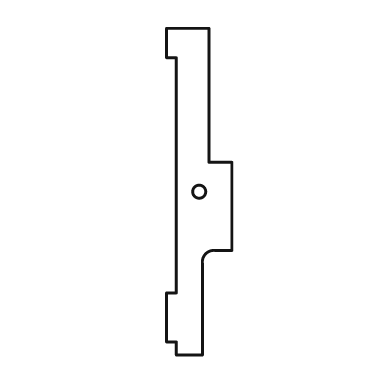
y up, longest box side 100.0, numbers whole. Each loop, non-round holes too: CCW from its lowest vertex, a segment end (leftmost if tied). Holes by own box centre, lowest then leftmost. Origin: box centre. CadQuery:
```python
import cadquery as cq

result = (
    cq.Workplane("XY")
    .moveTo(-7.0, -50.0)
    .lineTo(1.0, -50.0)
    .lineTo(1.0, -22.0)
    .threePointArc((2.0, -19.0), (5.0, -18.0))
    .lineTo(10.0, -18.0)
    .lineTo(10.0, 9.0)
    .lineTo(3.0, 9.0)
    .lineTo(3.0, 50.0)
    .lineTo(-10.0, 50.0)
    .lineTo(-10.0, 41.0)
    .lineTo(-7.0, 41.0)
    .lineTo(-7.0, -31.0)
    .lineTo(-10.0, -31.0)
    .lineTo(-10.0, -46.0)
    .lineTo(-7.0, -46.0)
    .close()
    .moveTo(0.0, 0.0)
    .circle(2.0)
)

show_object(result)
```